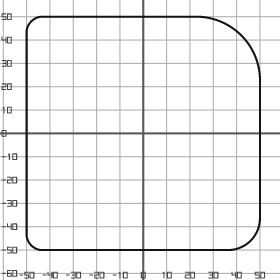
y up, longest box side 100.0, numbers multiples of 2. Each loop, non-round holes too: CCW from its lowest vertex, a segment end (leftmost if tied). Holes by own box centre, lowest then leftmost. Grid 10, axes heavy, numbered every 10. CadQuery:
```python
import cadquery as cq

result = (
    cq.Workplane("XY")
    .moveTo(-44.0, -50.0)
    .lineTo(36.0, -50.0)
    .threePointArc((46.0, -46.0), (50.0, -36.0))
    .lineTo(50.0, 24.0)
    .threePointArc((42.0, 42.0), (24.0, 50.0))
    .lineTo(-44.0, 50.0)
    .threePointArc((-48.0, 48.0), (-50.0, 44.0))
    .lineTo(-50.0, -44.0)
    .threePointArc((-48.0, -48.0), (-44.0, -50.0))
    .close()
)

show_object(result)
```